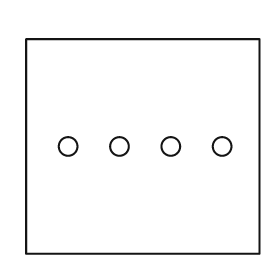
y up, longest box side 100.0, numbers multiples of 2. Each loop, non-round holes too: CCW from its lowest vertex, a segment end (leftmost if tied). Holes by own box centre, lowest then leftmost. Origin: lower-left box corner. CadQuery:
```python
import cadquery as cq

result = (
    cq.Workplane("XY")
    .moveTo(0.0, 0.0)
    .lineTo(100.0, 0.0)
    .lineTo(100.0, 92.0)
    .lineTo(0.0, 92.0)
    .close()
    .moveTo(18.0, 46.0)
    .circle(4.0)
    .moveTo(40.0, 46.0)
    .circle(4.0)
    .moveTo(62.0, 46.0)
    .circle(4.0)
    .moveTo(84.0, 46.0)
    .circle(4.0)
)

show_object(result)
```